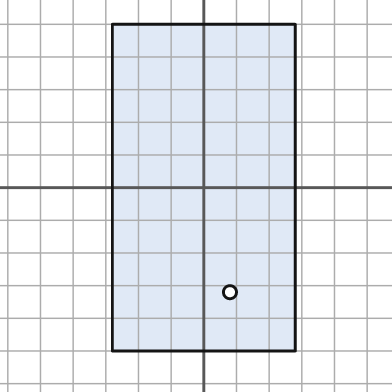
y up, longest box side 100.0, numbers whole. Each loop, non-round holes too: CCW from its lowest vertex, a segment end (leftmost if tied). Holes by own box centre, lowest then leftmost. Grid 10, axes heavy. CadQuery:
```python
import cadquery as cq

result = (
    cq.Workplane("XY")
    .moveTo(-28.0, -50.0)
    .lineTo(28.0, -50.0)
    .lineTo(28.0, 50.0)
    .lineTo(-28.0, 50.0)
    .close()
    .moveTo(8.0, -32.0)
    .circle(2.0)
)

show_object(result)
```